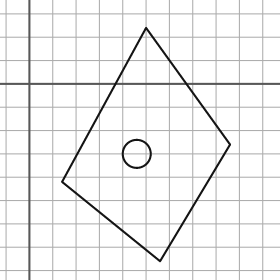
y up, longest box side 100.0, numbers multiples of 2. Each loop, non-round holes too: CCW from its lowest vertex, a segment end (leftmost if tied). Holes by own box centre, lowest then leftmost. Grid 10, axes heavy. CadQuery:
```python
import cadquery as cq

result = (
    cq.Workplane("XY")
    .moveTo(56.0, -76.0)
    .lineTo(86.0, -26.0)
    .lineTo(50.0, 24.0)
    .lineTo(14.0, -42.0)
    .close()
    .moveTo(46.0, -30.0)
    .circle(6.0)
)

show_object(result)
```